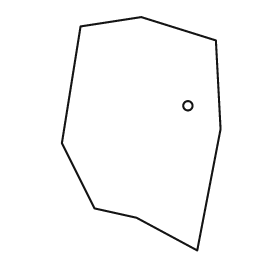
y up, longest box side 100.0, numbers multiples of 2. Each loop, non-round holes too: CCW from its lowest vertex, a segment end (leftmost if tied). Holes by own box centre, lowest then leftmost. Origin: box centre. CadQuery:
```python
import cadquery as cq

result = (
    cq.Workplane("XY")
    .moveTo(24.0, -50.0)
    .lineTo(34.0, 2.0)
    .lineTo(32.0, 40.0)
    .lineTo(0.0, 50.0)
    .lineTo(-26.0, 46.0)
    .lineTo(-34.0, -4.0)
    .lineTo(-20.0, -32.0)
    .lineTo(-2.0, -36.0)
    .close()
    .moveTo(20.0, 12.0)
    .circle(2.0)
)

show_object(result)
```